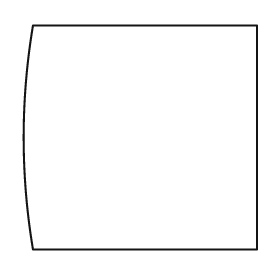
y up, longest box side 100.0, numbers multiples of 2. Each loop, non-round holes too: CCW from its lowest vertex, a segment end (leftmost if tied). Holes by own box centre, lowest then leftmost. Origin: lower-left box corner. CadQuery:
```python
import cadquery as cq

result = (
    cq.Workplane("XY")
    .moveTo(4.0, 0.0)
    .lineTo(100.0, 0.0)
    .lineTo(100.0, 96.0)
    .lineTo(4.0, 96.0)
    .threePointArc((0.0, 48.0), (4.0, 0.0))
    .close()
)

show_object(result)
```